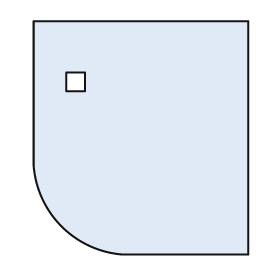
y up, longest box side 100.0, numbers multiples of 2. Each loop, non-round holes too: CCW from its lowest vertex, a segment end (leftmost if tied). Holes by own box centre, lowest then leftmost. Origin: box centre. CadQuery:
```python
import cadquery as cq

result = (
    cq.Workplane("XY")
    .moveTo(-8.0, -50.0)
    .lineTo(46.0, -50.0)
    .lineTo(46.0, 50.0)
    .lineTo(-46.0, 50.0)
    .lineTo(-46.0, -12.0)
    .threePointArc((-34.0, -38.0), (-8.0, -50.0))
    .close()
    .moveTo(-32.0, 20.0)
    .lineTo(-24.0, 20.0)
    .lineTo(-24.0, 28.0)
    .lineTo(-32.0, 28.0)
    .close()
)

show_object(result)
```